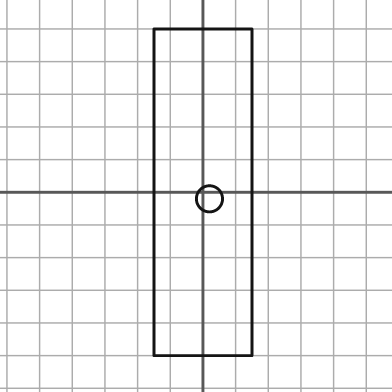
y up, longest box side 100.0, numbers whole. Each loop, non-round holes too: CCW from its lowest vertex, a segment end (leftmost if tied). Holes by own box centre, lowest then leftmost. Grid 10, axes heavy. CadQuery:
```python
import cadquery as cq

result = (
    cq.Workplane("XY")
    .moveTo(-15.0, -50.0)
    .lineTo(15.0, -50.0)
    .lineTo(15.0, 50.0)
    .lineTo(-15.0, 50.0)
    .close()
    .moveTo(2.0, -2.0)
    .circle(4.0)
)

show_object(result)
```